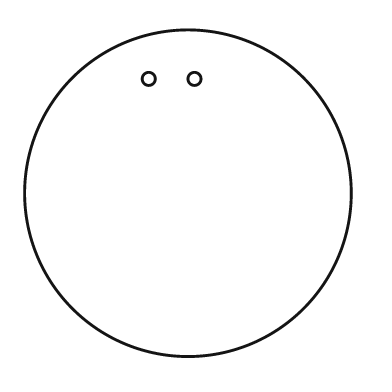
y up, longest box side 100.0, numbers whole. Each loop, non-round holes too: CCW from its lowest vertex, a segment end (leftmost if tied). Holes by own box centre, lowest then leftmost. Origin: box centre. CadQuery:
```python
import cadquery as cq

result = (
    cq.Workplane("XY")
    .moveTo(0.0, 0.0)
    .circle(50.0)
    .moveTo(-12.0, 35.0)
    .circle(2.0)
    .moveTo(2.0, 35.0)
    .circle(2.0)
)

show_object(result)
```